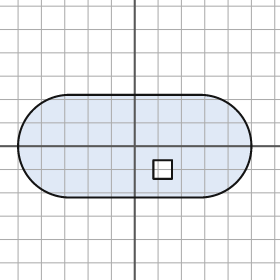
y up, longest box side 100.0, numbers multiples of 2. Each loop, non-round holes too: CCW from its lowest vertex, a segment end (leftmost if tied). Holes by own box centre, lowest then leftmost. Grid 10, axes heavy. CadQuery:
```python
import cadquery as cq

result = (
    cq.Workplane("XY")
    .moveTo(-28.0, -22.0)
    .lineTo(28.0, -22.0)
    .threePointArc((50.0, 0.0), (28.0, 22.0))
    .lineTo(-28.0, 22.0)
    .threePointArc((-50.0, 0.0), (-28.0, -22.0))
    .close()
    .moveTo(8.0, -14.0)
    .lineTo(16.0, -14.0)
    .lineTo(16.0, -6.0)
    .lineTo(8.0, -6.0)
    .close()
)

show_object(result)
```